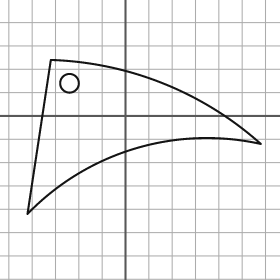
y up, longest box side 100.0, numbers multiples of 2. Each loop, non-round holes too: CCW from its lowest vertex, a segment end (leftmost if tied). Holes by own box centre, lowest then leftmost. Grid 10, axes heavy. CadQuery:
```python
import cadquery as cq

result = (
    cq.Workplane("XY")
    .moveTo(-42.0, -42.0)
    .threePointArc((4.0, -14.0), (58.0, -12.0))
    .threePointArc((16.0, 14.0), (-32.0, 24.0))
    .close()
    .moveTo(-24.0, 14.0)
    .circle(4.0)
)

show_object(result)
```